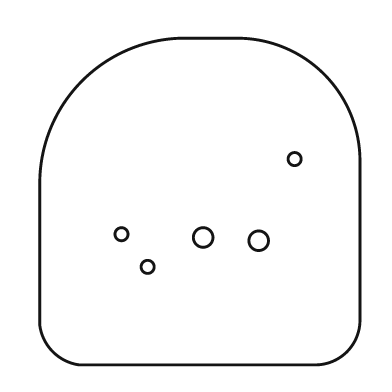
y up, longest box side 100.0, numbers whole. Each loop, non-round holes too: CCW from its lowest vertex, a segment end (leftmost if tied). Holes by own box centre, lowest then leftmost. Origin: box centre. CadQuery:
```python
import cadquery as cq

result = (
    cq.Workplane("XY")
    .moveTo(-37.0, -50.0)
    .lineTo(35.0, -50.0)
    .threePointArc((45.0, -46.0), (49.0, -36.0))
    .lineTo(49.0, 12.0)
    .threePointArc((38.0, 39.0), (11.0, 50.0))
    .lineTo(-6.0, 50.0)
    .threePointArc((-36.0, 37.0), (-49.0, 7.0))
    .lineTo(-49.0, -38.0)
    .threePointArc((-45.0, -46.0), (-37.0, -50.0))
    .close()
    .moveTo(-16.0, -20.0)
    .circle(2.0)
    .moveTo(18.0, -12.0)
    .circle(3.0)
    .moveTo(1.0, -11.0)
    .circle(3.0)
    .moveTo(-24.0, -10.0)
    .circle(2.0)
    .moveTo(29.0, 13.0)
    .circle(2.0)
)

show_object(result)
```